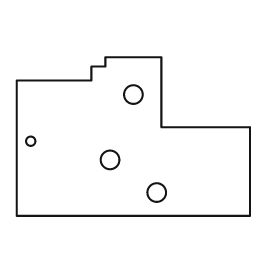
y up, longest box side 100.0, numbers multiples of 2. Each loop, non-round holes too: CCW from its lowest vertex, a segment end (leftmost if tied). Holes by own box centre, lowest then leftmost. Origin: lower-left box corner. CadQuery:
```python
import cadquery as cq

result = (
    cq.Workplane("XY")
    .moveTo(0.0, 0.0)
    .lineTo(100.0, 0.0)
    .lineTo(100.0, 38.0)
    .lineTo(62.0, 38.0)
    .lineTo(62.0, 68.0)
    .lineTo(38.0, 68.0)
    .lineTo(38.0, 64.0)
    .lineTo(32.0, 64.0)
    .lineTo(32.0, 58.0)
    .lineTo(0.0, 58.0)
    .close()
    .moveTo(60.0, 10.0)
    .circle(4.0)
    .moveTo(40.0, 24.0)
    .circle(4.0)
    .moveTo(6.0, 32.0)
    .circle(2.0)
    .moveTo(50.0, 52.0)
    .circle(4.0)
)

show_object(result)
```